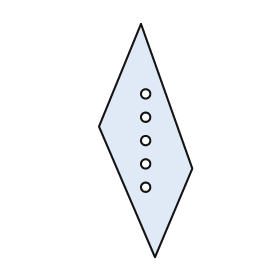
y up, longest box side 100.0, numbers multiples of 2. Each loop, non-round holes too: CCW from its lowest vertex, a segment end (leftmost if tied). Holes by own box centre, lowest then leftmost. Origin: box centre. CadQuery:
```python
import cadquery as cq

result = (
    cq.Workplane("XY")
    .moveTo(4.0, -50.0)
    .lineTo(20.0, -12.0)
    .lineTo(-2.0, 50.0)
    .lineTo(-20.0, 6.0)
    .close()
    .moveTo(0.0, -20.0)
    .circle(2.0)
    .moveTo(0.0, -10.0)
    .circle(2.0)
    .moveTo(0.0, 0.0)
    .circle(2.0)
    .moveTo(0.0, 10.0)
    .circle(2.0)
    .moveTo(0.0, 20.0)
    .circle(2.0)
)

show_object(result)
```